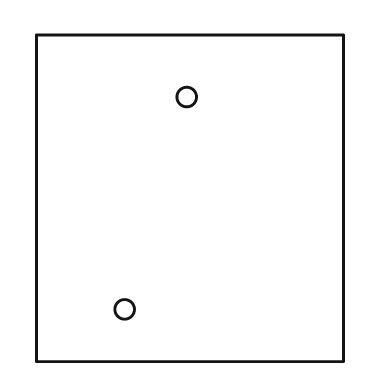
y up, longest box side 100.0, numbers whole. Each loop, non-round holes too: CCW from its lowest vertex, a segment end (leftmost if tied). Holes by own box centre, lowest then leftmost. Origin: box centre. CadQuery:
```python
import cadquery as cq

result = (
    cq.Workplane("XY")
    .moveTo(-47.0, -50.0)
    .lineTo(47.0, -50.0)
    .lineTo(47.0, 50.0)
    .lineTo(-47.0, 50.0)
    .close()
    .moveTo(-20.0, -34.0)
    .circle(3.0)
    .moveTo(-1.0, 31.0)
    .circle(3.0)
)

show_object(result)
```